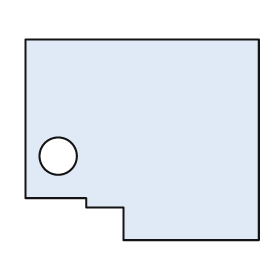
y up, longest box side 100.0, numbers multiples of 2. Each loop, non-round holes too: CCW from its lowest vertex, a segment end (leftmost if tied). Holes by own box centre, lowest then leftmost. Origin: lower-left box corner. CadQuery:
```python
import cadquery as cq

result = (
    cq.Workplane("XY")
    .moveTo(42.0, 0.0)
    .lineTo(100.0, 0.0)
    .lineTo(100.0, 86.0)
    .lineTo(0.0, 86.0)
    .lineTo(0.0, 18.0)
    .lineTo(26.0, 18.0)
    .lineTo(26.0, 14.0)
    .lineTo(42.0, 14.0)
    .close()
    .moveTo(14.0, 36.0)
    .circle(8.0)
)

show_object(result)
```